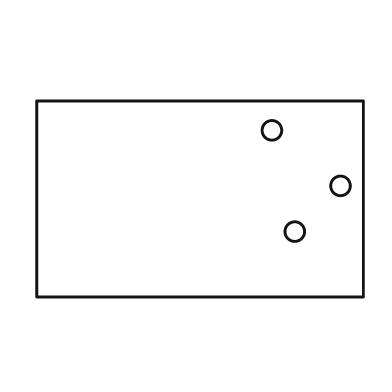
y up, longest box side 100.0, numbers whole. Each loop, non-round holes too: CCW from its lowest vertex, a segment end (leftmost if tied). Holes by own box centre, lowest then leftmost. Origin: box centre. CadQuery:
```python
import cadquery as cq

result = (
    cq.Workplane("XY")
    .moveTo(-50.0, -30.0)
    .lineTo(50.0, -30.0)
    .lineTo(50.0, 30.0)
    .lineTo(-50.0, 30.0)
    .close()
    .moveTo(29.0, -10.0)
    .circle(3.0)
    .moveTo(43.0, 4.0)
    .circle(3.0)
    .moveTo(22.0, 21.0)
    .circle(3.0)
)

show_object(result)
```